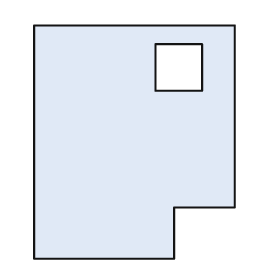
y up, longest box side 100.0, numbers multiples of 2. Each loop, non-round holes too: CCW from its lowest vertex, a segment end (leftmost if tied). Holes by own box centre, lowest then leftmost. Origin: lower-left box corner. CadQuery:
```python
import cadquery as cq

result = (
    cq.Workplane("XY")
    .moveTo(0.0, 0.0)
    .lineTo(60.0, 0.0)
    .lineTo(60.0, 22.0)
    .lineTo(86.0, 22.0)
    .lineTo(86.0, 100.0)
    .lineTo(0.0, 100.0)
    .close()
    .moveTo(52.0, 72.0)
    .lineTo(72.0, 72.0)
    .lineTo(72.0, 92.0)
    .lineTo(52.0, 92.0)
    .close()
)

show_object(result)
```